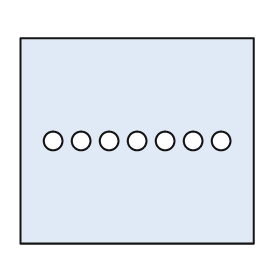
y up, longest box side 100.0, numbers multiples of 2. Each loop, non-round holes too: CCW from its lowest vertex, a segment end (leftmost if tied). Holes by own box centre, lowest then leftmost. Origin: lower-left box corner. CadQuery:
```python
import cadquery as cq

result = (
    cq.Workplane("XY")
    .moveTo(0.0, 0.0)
    .lineTo(100.0, 0.0)
    .lineTo(100.0, 88.0)
    .lineTo(0.0, 88.0)
    .close()
    .moveTo(14.0, 44.0)
    .circle(4.0)
    .moveTo(26.0, 44.0)
    .circle(4.0)
    .moveTo(38.0, 44.0)
    .circle(4.0)
    .moveTo(50.0, 44.0)
    .circle(4.0)
    .moveTo(62.0, 44.0)
    .circle(4.0)
    .moveTo(74.0, 44.0)
    .circle(4.0)
    .moveTo(86.0, 44.0)
    .circle(4.0)
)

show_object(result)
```